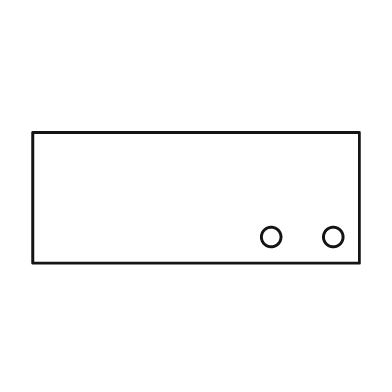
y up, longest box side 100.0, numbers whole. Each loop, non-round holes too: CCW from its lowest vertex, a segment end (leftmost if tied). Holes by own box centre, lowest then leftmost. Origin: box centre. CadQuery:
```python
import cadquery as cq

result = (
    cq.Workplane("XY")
    .moveTo(-50.0, -20.0)
    .lineTo(50.0, -20.0)
    .lineTo(50.0, 20.0)
    .lineTo(-50.0, 20.0)
    .close()
    .moveTo(23.0, -12.0)
    .circle(3.0)
    .moveTo(42.0, -12.0)
    .circle(3.0)
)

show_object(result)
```